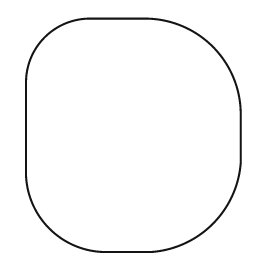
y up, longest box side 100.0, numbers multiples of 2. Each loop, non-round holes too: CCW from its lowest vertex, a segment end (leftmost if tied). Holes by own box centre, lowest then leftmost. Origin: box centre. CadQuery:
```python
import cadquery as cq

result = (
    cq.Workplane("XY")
    .moveTo(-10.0, -50.0)
    .lineTo(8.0, -50.0)
    .threePointArc((34.0, -38.0), (46.0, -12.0))
    .lineTo(46.0, 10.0)
    .threePointArc((34.0, 38.0), (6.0, 50.0))
    .lineTo(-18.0, 50.0)
    .threePointArc((-38.0, 42.0), (-46.0, 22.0))
    .lineTo(-46.0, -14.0)
    .threePointArc((-36.0, -40.0), (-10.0, -50.0))
    .close()
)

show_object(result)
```